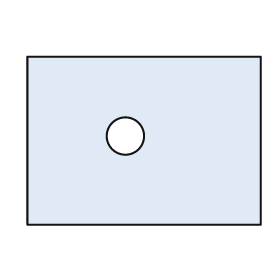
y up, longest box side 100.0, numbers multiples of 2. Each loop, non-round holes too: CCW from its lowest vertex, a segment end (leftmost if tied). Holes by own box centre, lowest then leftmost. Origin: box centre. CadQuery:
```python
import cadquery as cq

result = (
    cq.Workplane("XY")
    .moveTo(-50.0, -36.0)
    .lineTo(50.0, -36.0)
    .lineTo(50.0, 36.0)
    .lineTo(-50.0, 36.0)
    .close()
    .moveTo(-8.0, 2.0)
    .circle(8.0)
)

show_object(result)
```